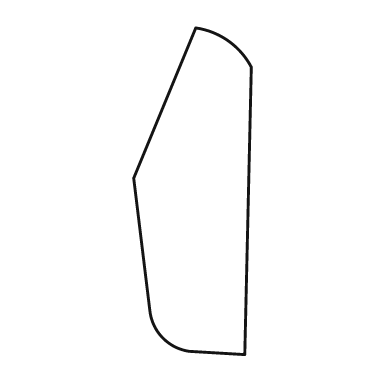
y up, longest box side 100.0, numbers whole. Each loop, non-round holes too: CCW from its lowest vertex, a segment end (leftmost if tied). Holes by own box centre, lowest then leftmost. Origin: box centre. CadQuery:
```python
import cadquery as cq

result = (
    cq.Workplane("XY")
    .moveTo(16.0, -50.0)
    .lineTo(18.0, 38.0)
    .threePointArc((11.0, 46.0), (1.0, 50.0))
    .lineTo(-18.0, 4.0)
    .lineTo(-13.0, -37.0)
    .threePointArc((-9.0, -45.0), (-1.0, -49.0))
    .close()
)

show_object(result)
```